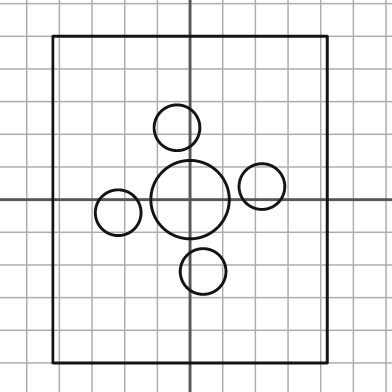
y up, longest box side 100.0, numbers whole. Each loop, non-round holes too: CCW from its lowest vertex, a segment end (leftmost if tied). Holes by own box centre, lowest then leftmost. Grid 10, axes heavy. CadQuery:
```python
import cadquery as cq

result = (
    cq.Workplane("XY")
    .moveTo(-42.0, -50.0)
    .lineTo(42.0, -50.0)
    .lineTo(42.0, 50.0)
    .lineTo(-42.0, 50.0)
    .close()
    .moveTo(4.0, -22.0)
    .circle(7.0)
    .moveTo(-22.0, -4.0)
    .circle(7.0)
    .moveTo(0.0, 0.0)
    .circle(12.0)
    .moveTo(22.0, 4.0)
    .circle(7.0)
    .moveTo(-4.0, 22.0)
    .circle(7.0)
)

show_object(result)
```